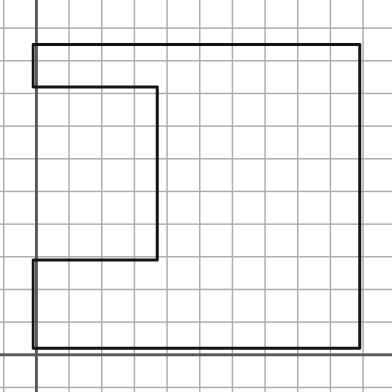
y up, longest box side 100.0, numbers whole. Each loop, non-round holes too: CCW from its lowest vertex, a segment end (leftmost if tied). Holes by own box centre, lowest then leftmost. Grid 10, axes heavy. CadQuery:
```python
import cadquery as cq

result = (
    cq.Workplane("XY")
    .moveTo(-1.0, 2.0)
    .lineTo(99.0, 2.0)
    .lineTo(99.0, 95.0)
    .lineTo(-1.0, 95.0)
    .lineTo(-1.0, 82.0)
    .lineTo(37.0, 82.0)
    .lineTo(37.0, 29.0)
    .lineTo(-1.0, 29.0)
    .close()
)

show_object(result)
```